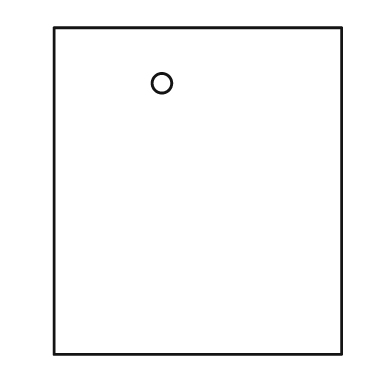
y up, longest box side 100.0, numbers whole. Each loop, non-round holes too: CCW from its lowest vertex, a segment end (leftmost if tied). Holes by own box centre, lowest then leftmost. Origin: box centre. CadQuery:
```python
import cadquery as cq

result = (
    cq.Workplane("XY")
    .moveTo(-44.0, -50.0)
    .lineTo(44.0, -50.0)
    .lineTo(44.0, 50.0)
    .lineTo(-44.0, 50.0)
    .close()
    .moveTo(-11.0, 33.0)
    .circle(3.0)
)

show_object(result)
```